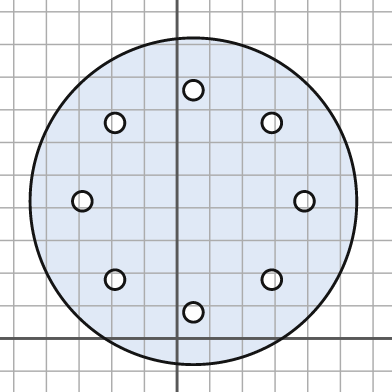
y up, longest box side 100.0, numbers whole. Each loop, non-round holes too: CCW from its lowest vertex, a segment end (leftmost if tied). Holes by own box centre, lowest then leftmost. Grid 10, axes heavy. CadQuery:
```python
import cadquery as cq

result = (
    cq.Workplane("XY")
    .moveTo(5.0, 42.0)
    .circle(50.0)
    .moveTo(5.0, 8.0)
    .circle(3.0)
    .moveTo(-19.0, 18.0)
    .circle(3.0)
    .moveTo(29.0, 18.0)
    .circle(3.0)
    .moveTo(-29.0, 42.0)
    .circle(3.0)
    .moveTo(39.0, 42.0)
    .circle(3.0)
    .moveTo(-19.0, 66.0)
    .circle(3.0)
    .moveTo(29.0, 66.0)
    .circle(3.0)
    .moveTo(5.0, 76.0)
    .circle(3.0)
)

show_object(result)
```